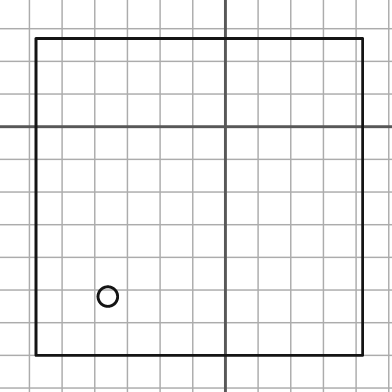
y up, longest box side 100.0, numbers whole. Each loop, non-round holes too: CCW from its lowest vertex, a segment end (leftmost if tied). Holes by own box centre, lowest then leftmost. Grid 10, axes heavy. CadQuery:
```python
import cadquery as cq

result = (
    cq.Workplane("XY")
    .moveTo(-58.0, -70.0)
    .lineTo(42.0, -70.0)
    .lineTo(42.0, 27.0)
    .lineTo(-58.0, 27.0)
    .close()
    .moveTo(-36.0, -52.0)
    .circle(3.0)
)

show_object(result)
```